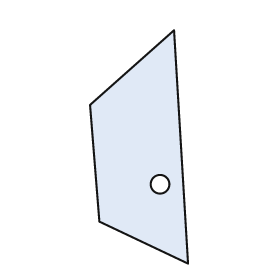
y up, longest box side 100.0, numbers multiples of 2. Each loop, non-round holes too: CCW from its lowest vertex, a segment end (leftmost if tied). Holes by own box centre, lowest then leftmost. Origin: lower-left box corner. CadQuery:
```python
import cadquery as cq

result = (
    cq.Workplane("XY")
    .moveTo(42.0, 0.0)
    .lineTo(36.0, 100.0)
    .lineTo(0.0, 68.0)
    .lineTo(4.0, 18.0)
    .close()
    .moveTo(30.0, 34.0)
    .circle(4.0)
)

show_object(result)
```